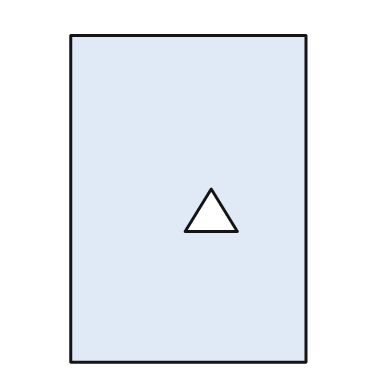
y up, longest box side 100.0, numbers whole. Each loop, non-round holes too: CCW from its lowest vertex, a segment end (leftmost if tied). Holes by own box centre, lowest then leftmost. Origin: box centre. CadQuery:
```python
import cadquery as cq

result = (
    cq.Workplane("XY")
    .moveTo(-36.0, -50.0)
    .lineTo(36.0, -50.0)
    .lineTo(36.0, 50.0)
    .lineTo(-36.0, 50.0)
    .close()
    .moveTo(-1.0, -10.0)
    .lineTo(15.0, -10.0)
    .lineTo(7.0, 3.0)
    .close()
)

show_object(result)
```